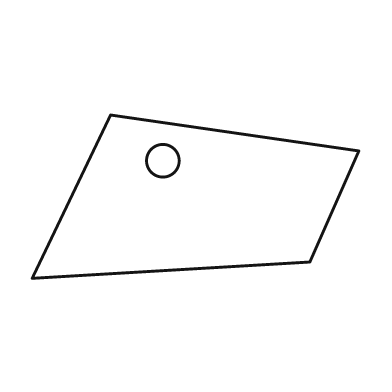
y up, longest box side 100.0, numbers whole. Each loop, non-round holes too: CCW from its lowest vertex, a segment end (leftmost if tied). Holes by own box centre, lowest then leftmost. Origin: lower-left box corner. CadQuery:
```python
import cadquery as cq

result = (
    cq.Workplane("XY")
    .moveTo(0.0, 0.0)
    .lineTo(85.0, 5.0)
    .lineTo(100.0, 39.0)
    .lineTo(24.0, 50.0)
    .close()
    .moveTo(40.0, 36.0)
    .circle(5.0)
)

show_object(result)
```